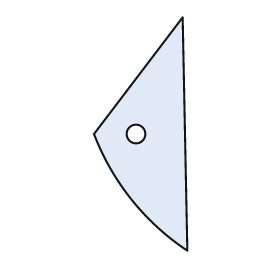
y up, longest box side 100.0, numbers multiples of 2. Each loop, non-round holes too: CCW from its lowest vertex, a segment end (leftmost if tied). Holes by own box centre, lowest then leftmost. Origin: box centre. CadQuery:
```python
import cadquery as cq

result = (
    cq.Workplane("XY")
    .moveTo(20.0, -50.0)
    .lineTo(18.0, 50.0)
    .lineTo(-20.0, 0.0)
    .threePointArc((-4.0, -28.0), (20.0, -50.0))
    .close()
    .moveTo(-2.0, 0.0)
    .circle(4.0)
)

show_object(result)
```